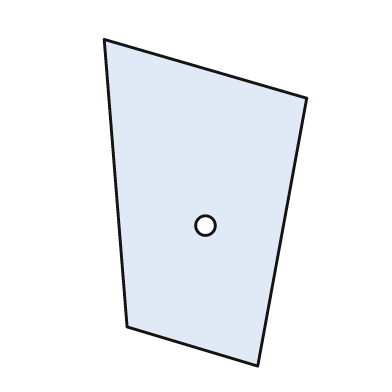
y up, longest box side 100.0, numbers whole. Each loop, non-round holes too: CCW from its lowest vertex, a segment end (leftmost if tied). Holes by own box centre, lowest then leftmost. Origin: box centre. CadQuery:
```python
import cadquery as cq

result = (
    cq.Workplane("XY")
    .moveTo(16.0, -50.0)
    .lineTo(31.0, 32.0)
    .lineTo(-31.0, 50.0)
    .lineTo(-24.0, -38.0)
    .close()
    .moveTo(0.0, -7.0)
    .circle(3.0)
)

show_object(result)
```